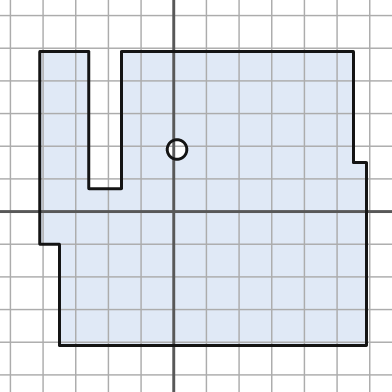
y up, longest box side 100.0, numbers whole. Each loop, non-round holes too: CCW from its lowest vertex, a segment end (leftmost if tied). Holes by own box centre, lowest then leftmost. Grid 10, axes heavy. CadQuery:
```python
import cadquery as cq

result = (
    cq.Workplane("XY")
    .moveTo(-35.0, -41.0)
    .lineTo(59.0, -41.0)
    .lineTo(59.0, 15.0)
    .lineTo(55.0, 15.0)
    .lineTo(55.0, 49.0)
    .lineTo(-16.0, 49.0)
    .lineTo(-16.0, 7.0)
    .lineTo(-26.0, 7.0)
    .lineTo(-26.0, 49.0)
    .lineTo(-41.0, 49.0)
    .lineTo(-41.0, -10.0)
    .lineTo(-35.0, -10.0)
    .close()
    .moveTo(1.0, 19.0)
    .circle(3.0)
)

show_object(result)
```